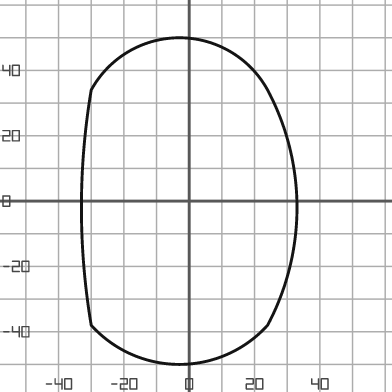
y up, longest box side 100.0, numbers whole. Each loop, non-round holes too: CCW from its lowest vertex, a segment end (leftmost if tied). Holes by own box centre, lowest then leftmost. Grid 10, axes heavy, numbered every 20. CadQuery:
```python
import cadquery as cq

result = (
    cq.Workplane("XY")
    .moveTo(-30.0, -38.0)
    .threePointArc((-3.0, -50.0), (24.0, -38.0))
    .threePointArc((33.0, -2.0), (24.0, 34.0))
    .threePointArc((-3.0, 50.0), (-30.0, 34.0))
    .threePointArc((-33.0, -2.0), (-30.0, -38.0))
    .close()
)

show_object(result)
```